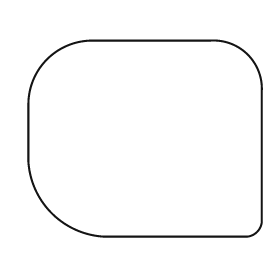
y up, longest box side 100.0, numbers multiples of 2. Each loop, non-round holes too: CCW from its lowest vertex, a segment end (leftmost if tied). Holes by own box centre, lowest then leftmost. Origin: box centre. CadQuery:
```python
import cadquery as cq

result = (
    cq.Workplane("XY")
    .moveTo(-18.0, -42.0)
    .lineTo(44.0, -42.0)
    .threePointArc((48.0, -40.0), (50.0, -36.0))
    .lineTo(50.0, 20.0)
    .threePointArc((44.0, 36.0), (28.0, 42.0))
    .lineTo(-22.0, 42.0)
    .threePointArc((-42.0, 34.0), (-50.0, 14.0))
    .lineTo(-50.0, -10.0)
    .threePointArc((-40.0, -32.0), (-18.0, -42.0))
    .close()
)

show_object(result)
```